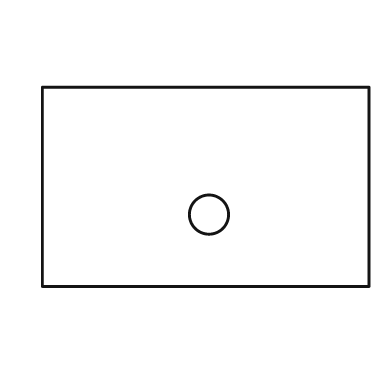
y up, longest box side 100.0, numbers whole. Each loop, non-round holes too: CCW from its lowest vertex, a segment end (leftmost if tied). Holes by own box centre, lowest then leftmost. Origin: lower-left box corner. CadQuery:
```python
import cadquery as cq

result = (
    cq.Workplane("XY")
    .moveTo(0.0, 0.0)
    .lineTo(100.0, 0.0)
    .lineTo(100.0, 61.0)
    .lineTo(0.0, 61.0)
    .close()
    .moveTo(51.0, 22.0)
    .circle(6.0)
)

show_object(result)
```